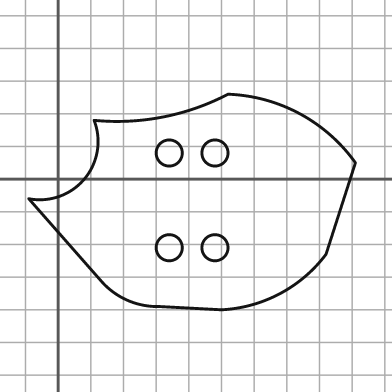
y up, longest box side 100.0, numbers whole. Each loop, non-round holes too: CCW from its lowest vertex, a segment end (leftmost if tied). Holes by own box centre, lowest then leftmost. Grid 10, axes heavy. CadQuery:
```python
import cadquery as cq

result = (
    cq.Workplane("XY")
    .moveTo(50.0, -40.0)
    .threePointArc((68.0, -35.0), (82.0, -23.0))
    .lineTo(91.0, 5.0)
    .threePointArc((74.0, 20.0), (52.0, 26.0))
    .threePointArc((32.0, 19.0), (11.0, 18.0))
    .threePointArc((8.0, 0.0), (-9.0, -6.0))
    .lineTo(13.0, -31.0)
    .threePointArc((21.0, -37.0), (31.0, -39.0))
    .close()
    .moveTo(34.0, -21.0)
    .circle(4.0)
    .moveTo(48.0, -21.0)
    .circle(4.0)
    .moveTo(34.0, 8.0)
    .circle(4.0)
    .moveTo(48.0, 8.0)
    .circle(4.0)
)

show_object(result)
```